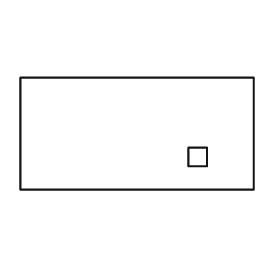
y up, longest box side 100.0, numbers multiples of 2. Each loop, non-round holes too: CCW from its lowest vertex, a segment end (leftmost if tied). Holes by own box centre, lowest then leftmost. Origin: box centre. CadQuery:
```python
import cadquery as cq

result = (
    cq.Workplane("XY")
    .moveTo(-50.0, -24.0)
    .lineTo(50.0, -24.0)
    .lineTo(50.0, 24.0)
    .lineTo(-50.0, 24.0)
    .close()
    .moveTo(22.0, -14.0)
    .lineTo(30.0, -14.0)
    .lineTo(30.0, -6.0)
    .lineTo(22.0, -6.0)
    .close()
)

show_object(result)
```